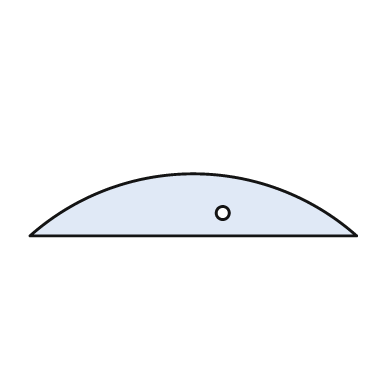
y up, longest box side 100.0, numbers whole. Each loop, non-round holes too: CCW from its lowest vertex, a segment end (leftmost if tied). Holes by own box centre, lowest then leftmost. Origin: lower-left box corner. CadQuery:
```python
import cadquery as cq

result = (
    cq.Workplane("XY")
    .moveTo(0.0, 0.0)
    .lineTo(100.0, 0.0)
    .threePointArc((50.0, 19.0), (0.0, 0.0))
    .close()
    .moveTo(59.0, 7.0)
    .circle(2.0)
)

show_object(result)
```